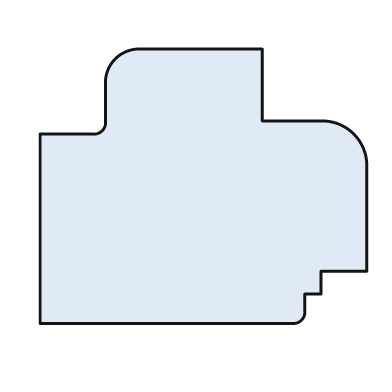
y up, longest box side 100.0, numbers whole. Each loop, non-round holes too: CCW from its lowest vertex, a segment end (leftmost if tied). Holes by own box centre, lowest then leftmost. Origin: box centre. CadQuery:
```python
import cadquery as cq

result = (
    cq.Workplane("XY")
    .moveTo(-50.0, -42.0)
    .lineTo(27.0, -42.0)
    .threePointArc((30.0, -41.0), (31.0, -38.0))
    .lineTo(31.0, -33.0)
    .lineTo(36.0, -33.0)
    .lineTo(36.0, -26.0)
    .lineTo(50.0, -26.0)
    .lineTo(50.0, 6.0)
    .threePointArc((46.0, 16.0), (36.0, 20.0))
    .lineTo(18.0, 20.0)
    .lineTo(18.0, 42.0)
    .lineTo(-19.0, 42.0)
    .threePointArc((-27.0, 39.0), (-30.0, 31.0))
    .lineTo(-30.0, 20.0)
    .threePointArc((-31.0, 17.0), (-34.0, 16.0))
    .lineTo(-50.0, 16.0)
    .close()
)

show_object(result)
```